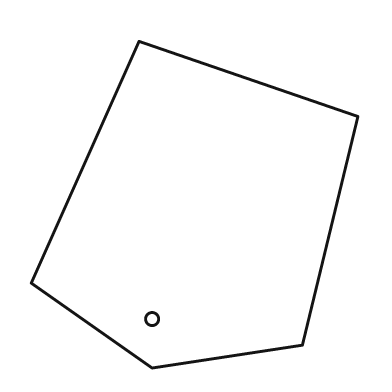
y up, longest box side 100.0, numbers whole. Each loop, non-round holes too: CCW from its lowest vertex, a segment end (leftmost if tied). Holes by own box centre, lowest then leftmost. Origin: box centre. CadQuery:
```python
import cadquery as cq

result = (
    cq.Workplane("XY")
    .moveTo(-13.0, -50.0)
    .lineTo(33.0, -43.0)
    .lineTo(50.0, 27.0)
    .lineTo(-17.0, 50.0)
    .lineTo(-50.0, -24.0)
    .close()
    .moveTo(-13.0, -35.0)
    .circle(2.0)
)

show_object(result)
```